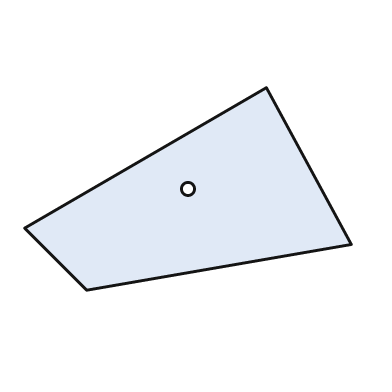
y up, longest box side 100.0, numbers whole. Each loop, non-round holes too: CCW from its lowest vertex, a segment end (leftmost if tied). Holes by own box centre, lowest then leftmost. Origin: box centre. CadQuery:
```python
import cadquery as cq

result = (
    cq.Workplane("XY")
    .moveTo(-31.0, -31.0)
    .lineTo(50.0, -17.0)
    .lineTo(24.0, 31.0)
    .lineTo(-50.0, -12.0)
    .close()
    .moveTo(0.0, 0.0)
    .circle(2.0)
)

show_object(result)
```